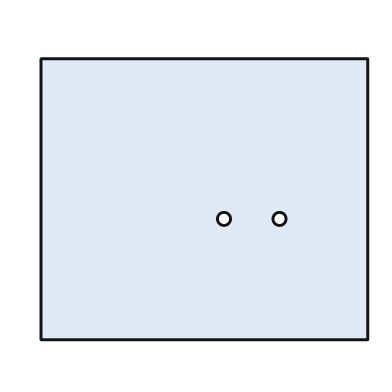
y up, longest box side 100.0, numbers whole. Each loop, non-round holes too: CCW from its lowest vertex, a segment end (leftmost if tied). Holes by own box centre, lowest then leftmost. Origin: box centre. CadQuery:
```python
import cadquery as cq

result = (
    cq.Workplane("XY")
    .moveTo(-50.0, -43.0)
    .lineTo(50.0, -43.0)
    .lineTo(50.0, 43.0)
    .lineTo(-50.0, 43.0)
    .close()
    .moveTo(6.0, -6.0)
    .circle(2.0)
    .moveTo(23.0, -6.0)
    .circle(2.0)
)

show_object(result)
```